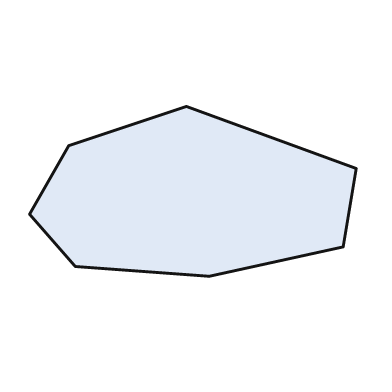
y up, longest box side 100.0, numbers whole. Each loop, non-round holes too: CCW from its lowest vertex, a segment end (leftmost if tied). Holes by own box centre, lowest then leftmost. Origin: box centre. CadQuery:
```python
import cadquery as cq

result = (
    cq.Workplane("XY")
    .moveTo(5.0, -26.0)
    .lineTo(46.0, -17.0)
    .lineTo(50.0, 7.0)
    .lineTo(-2.0, 26.0)
    .lineTo(-38.0, 14.0)
    .lineTo(-50.0, -7.0)
    .lineTo(-36.0, -23.0)
    .close()
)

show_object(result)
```